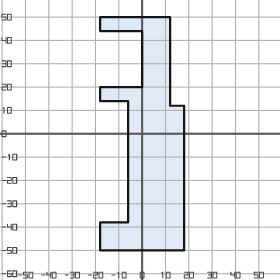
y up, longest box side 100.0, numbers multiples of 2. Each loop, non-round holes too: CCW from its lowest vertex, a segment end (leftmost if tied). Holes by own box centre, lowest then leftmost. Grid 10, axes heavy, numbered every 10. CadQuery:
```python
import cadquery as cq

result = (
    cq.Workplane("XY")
    .moveTo(-18.0, -50.0)
    .lineTo(18.0, -50.0)
    .lineTo(18.0, 12.0)
    .lineTo(12.0, 12.0)
    .lineTo(12.0, 50.0)
    .lineTo(-18.0, 50.0)
    .lineTo(-18.0, 44.0)
    .lineTo(0.0, 44.0)
    .lineTo(0.0, 20.0)
    .lineTo(-18.0, 20.0)
    .lineTo(-18.0, 14.0)
    .lineTo(-6.0, 14.0)
    .lineTo(-6.0, -38.0)
    .lineTo(-18.0, -38.0)
    .close()
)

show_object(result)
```